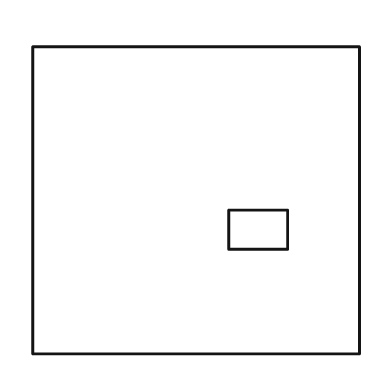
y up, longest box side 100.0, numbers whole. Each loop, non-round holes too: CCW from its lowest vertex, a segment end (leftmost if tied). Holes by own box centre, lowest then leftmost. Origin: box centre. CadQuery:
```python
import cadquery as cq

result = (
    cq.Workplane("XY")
    .moveTo(-50.0, -47.0)
    .lineTo(50.0, -47.0)
    .lineTo(50.0, 47.0)
    .lineTo(-50.0, 47.0)
    .close()
    .moveTo(10.0, -15.0)
    .lineTo(28.0, -15.0)
    .lineTo(28.0, -3.0)
    .lineTo(10.0, -3.0)
    .close()
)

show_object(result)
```